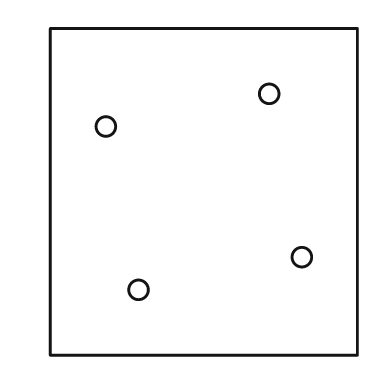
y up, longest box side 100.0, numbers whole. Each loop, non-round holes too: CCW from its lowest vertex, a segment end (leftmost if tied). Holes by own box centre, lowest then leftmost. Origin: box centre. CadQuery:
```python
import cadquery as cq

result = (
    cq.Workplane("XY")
    .moveTo(-47.0, -50.0)
    .lineTo(47.0, -50.0)
    .lineTo(47.0, 50.0)
    .lineTo(-47.0, 50.0)
    .close()
    .moveTo(-20.0, -30.0)
    .circle(3.0)
    .moveTo(30.0, -20.0)
    .circle(3.0)
    .moveTo(-30.0, 20.0)
    .circle(3.0)
    .moveTo(20.0, 30.0)
    .circle(3.0)
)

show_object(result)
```